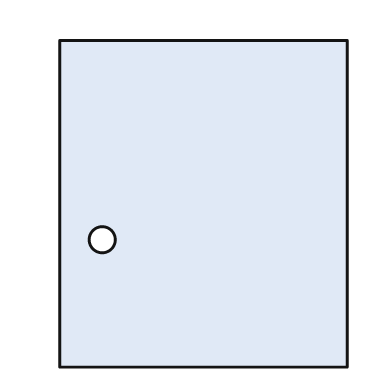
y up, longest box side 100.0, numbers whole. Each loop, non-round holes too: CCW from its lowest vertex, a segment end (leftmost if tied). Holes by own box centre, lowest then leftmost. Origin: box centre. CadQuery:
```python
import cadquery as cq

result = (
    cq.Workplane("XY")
    .moveTo(-44.0, -50.0)
    .lineTo(44.0, -50.0)
    .lineTo(44.0, 50.0)
    .lineTo(-44.0, 50.0)
    .close()
    .moveTo(-31.0, -11.0)
    .circle(4.0)
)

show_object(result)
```